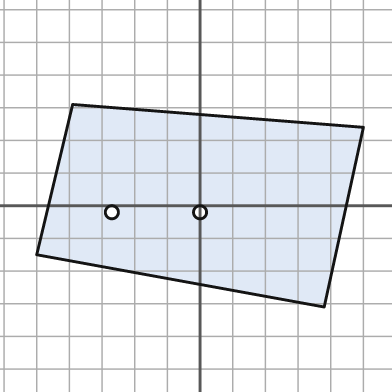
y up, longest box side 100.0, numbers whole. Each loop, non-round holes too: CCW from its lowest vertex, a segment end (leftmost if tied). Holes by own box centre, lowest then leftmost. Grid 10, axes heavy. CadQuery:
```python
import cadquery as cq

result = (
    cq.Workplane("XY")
    .moveTo(38.0, -31.0)
    .lineTo(50.0, 24.0)
    .lineTo(-39.0, 31.0)
    .lineTo(-50.0, -15.0)
    .close()
    .moveTo(-27.0, -2.0)
    .circle(2.0)
    .moveTo(0.0, -2.0)
    .circle(2.0)
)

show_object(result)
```